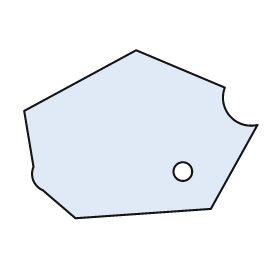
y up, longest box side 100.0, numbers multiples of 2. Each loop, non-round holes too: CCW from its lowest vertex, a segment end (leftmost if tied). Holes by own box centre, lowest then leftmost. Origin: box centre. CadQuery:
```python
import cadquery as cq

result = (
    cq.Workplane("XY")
    .moveTo(-28.0, -36.0)
    .lineTo(30.0, -32.0)
    .lineTo(50.0, 4.0)
    .threePointArc((38.0, 8.0), (36.0, 20.0))
    .lineTo(-2.0, 36.0)
    .lineTo(-50.0, 10.0)
    .lineTo(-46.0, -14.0)
    .threePointArc((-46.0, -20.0), (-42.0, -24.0))
    .close()
    .moveTo(18.0, -16.0)
    .circle(4.0)
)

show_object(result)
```